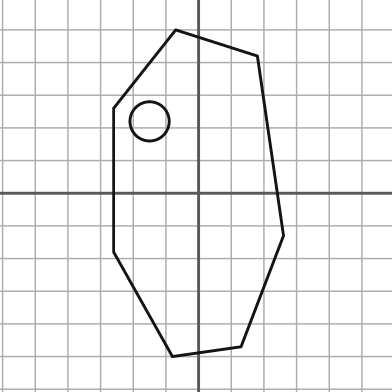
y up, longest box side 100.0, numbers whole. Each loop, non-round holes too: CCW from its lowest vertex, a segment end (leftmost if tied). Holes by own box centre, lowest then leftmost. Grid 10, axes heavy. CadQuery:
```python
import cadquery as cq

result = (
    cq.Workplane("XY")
    .moveTo(-8.0, -50.0)
    .lineTo(13.0, -47.0)
    .lineTo(26.0, -13.0)
    .lineTo(18.0, 42.0)
    .lineTo(-7.0, 50.0)
    .lineTo(-26.0, 26.0)
    .lineTo(-26.0, -18.0)
    .close()
    .moveTo(-15.0, 22.0)
    .circle(6.0)
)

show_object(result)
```